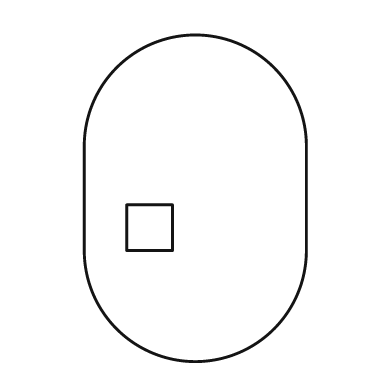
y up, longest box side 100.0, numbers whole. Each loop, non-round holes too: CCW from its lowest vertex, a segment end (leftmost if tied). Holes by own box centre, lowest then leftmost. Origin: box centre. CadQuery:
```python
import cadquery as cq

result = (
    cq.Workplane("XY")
    .moveTo(-34.0, -16.0)
    .threePointArc((0.0, -50.0), (34.0, -16.0))
    .lineTo(34.0, 16.0)
    .threePointArc((0.0, 50.0), (-34.0, 16.0))
    .close()
    .moveTo(-21.0, -16.0)
    .lineTo(-7.0, -16.0)
    .lineTo(-7.0, -2.0)
    .lineTo(-21.0, -2.0)
    .close()
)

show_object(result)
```